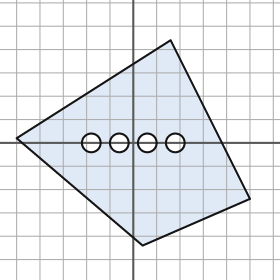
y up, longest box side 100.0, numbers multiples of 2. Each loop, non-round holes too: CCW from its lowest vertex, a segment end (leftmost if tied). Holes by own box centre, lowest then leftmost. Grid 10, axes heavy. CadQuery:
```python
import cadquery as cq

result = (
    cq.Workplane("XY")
    .moveTo(4.0, -44.0)
    .lineTo(50.0, -24.0)
    .lineTo(16.0, 44.0)
    .lineTo(-50.0, 2.0)
    .close()
    .moveTo(-18.0, 0.0)
    .circle(4.0)
    .moveTo(-6.0, 0.0)
    .circle(4.0)
    .moveTo(6.0, 0.0)
    .circle(4.0)
    .moveTo(18.0, 0.0)
    .circle(4.0)
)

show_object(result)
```